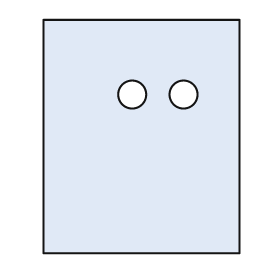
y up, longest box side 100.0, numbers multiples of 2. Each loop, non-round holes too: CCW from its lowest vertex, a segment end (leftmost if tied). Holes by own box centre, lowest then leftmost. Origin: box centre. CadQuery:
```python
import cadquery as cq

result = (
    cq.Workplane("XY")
    .moveTo(-42.0, -50.0)
    .lineTo(42.0, -50.0)
    .lineTo(42.0, 50.0)
    .lineTo(-42.0, 50.0)
    .close()
    .moveTo(-4.0, 18.0)
    .circle(6.0)
    .moveTo(18.0, 18.0)
    .circle(6.0)
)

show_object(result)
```